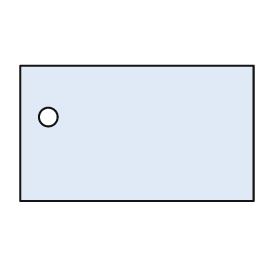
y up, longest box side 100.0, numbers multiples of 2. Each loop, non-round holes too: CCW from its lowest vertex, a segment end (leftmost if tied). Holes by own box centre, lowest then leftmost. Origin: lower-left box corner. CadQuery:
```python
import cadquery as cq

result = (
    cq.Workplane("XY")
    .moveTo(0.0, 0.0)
    .lineTo(100.0, 0.0)
    .lineTo(100.0, 58.0)
    .lineTo(0.0, 58.0)
    .close()
    .moveTo(12.0, 36.0)
    .circle(4.0)
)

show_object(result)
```